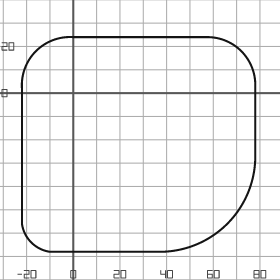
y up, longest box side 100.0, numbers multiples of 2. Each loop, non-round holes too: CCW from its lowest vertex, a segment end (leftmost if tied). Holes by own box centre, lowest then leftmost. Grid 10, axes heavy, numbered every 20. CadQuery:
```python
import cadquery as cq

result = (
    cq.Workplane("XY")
    .moveTo(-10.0, -68.0)
    .lineTo(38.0, -68.0)
    .threePointArc((66.0, -56.0), (78.0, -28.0))
    .lineTo(78.0, 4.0)
    .threePointArc((72.0, 18.0), (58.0, 24.0))
    .lineTo(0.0, 24.0)
    .threePointArc((-16.0, 18.0), (-22.0, 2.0))
    .lineTo(-22.0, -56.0)
    .threePointArc((-18.0, -64.0), (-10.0, -68.0))
    .close()
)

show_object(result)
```